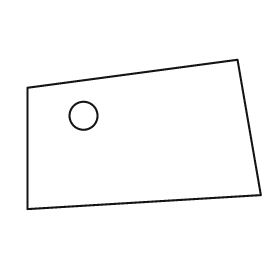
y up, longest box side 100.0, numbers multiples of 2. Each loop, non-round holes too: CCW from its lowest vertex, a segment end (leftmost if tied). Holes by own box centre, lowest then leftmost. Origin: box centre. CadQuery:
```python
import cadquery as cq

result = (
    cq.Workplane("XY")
    .moveTo(-50.0, -32.0)
    .lineTo(50.0, -26.0)
    .lineTo(40.0, 32.0)
    .lineTo(-50.0, 20.0)
    .close()
    .moveTo(-26.0, 8.0)
    .circle(6.0)
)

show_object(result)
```